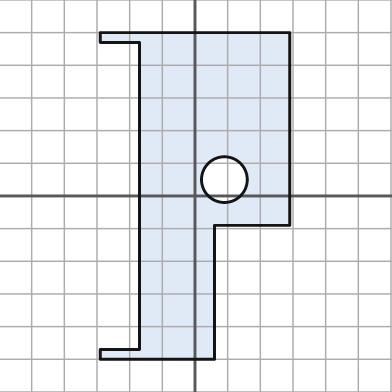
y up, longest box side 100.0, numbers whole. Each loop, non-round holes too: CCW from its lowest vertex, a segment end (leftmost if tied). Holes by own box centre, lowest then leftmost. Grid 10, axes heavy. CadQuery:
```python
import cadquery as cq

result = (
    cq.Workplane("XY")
    .moveTo(-29.0, -50.0)
    .lineTo(6.0, -50.0)
    .lineTo(6.0, -9.0)
    .lineTo(29.0, -9.0)
    .lineTo(29.0, 50.0)
    .lineTo(-29.0, 50.0)
    .lineTo(-29.0, 47.0)
    .lineTo(-17.0, 47.0)
    .lineTo(-17.0, -47.0)
    .lineTo(-29.0, -47.0)
    .close()
    .moveTo(9.0, 5.0)
    .circle(7.0)
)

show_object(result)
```